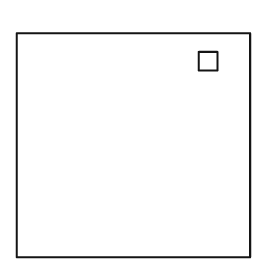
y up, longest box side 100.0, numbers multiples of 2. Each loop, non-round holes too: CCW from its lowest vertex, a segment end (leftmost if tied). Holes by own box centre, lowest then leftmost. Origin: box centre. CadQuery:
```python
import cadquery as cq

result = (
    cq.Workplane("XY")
    .moveTo(-50.0, -48.0)
    .lineTo(50.0, -48.0)
    .lineTo(50.0, 48.0)
    .lineTo(-50.0, 48.0)
    .close()
    .moveTo(28.0, 32.0)
    .lineTo(36.0, 32.0)
    .lineTo(36.0, 40.0)
    .lineTo(28.0, 40.0)
    .close()
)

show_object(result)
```